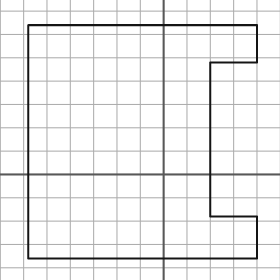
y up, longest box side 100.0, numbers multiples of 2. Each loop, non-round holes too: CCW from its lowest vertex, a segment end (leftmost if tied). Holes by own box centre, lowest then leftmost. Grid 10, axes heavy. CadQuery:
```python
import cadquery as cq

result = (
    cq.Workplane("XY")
    .moveTo(-58.0, -36.0)
    .lineTo(40.0, -36.0)
    .lineTo(40.0, -18.0)
    .lineTo(20.0, -18.0)
    .lineTo(20.0, 48.0)
    .lineTo(40.0, 48.0)
    .lineTo(40.0, 64.0)
    .lineTo(-58.0, 64.0)
    .close()
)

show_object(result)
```